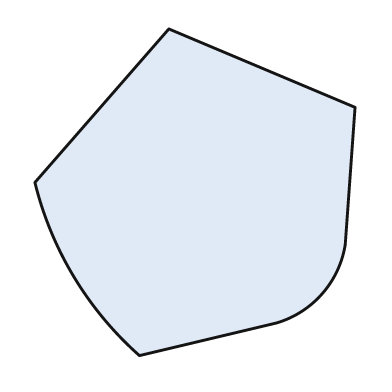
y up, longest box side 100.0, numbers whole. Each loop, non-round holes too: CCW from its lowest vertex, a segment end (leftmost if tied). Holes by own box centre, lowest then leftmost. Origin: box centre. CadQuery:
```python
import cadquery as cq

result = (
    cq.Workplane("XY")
    .moveTo(-17.0, -50.0)
    .lineTo(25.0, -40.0)
    .threePointArc((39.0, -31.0), (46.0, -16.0))
    .lineTo(49.0, 26.0)
    .lineTo(-8.0, 50.0)
    .lineTo(-49.0, 3.0)
    .threePointArc((-37.0, -26.0), (-17.0, -50.0))
    .close()
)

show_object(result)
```